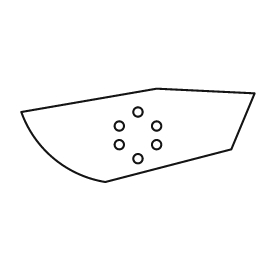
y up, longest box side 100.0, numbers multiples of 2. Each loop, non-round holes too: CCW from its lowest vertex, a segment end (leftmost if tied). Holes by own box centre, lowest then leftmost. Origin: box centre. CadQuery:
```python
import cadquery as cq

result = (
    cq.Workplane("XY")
    .moveTo(-14.0, -20.0)
    .lineTo(40.0, -6.0)
    .lineTo(50.0, 18.0)
    .lineTo(8.0, 20.0)
    .lineTo(-50.0, 10.0)
    .threePointArc((-36.0, -10.0), (-14.0, -20.0))
    .close()
    .moveTo(0.0, -10.0)
    .circle(2.0)
    .moveTo(-8.0, -4.0)
    .circle(2.0)
    .moveTo(8.0, -4.0)
    .circle(2.0)
    .moveTo(-8.0, 4.0)
    .circle(2.0)
    .moveTo(8.0, 4.0)
    .circle(2.0)
    .moveTo(0.0, 10.0)
    .circle(2.0)
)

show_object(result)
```